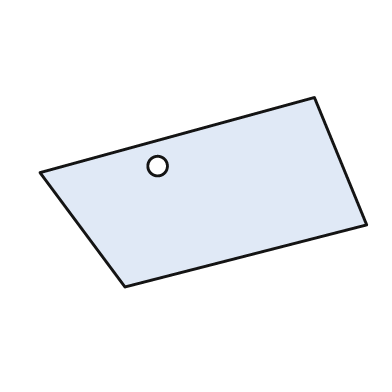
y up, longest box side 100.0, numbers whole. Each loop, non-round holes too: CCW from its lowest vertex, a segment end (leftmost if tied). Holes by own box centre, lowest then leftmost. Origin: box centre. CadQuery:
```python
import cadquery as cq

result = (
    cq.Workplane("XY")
    .moveTo(-24.0, -29.0)
    .lineTo(50.0, -10.0)
    .lineTo(34.0, 29.0)
    .lineTo(-50.0, 6.0)
    .close()
    .moveTo(-14.0, 8.0)
    .circle(3.0)
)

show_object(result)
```